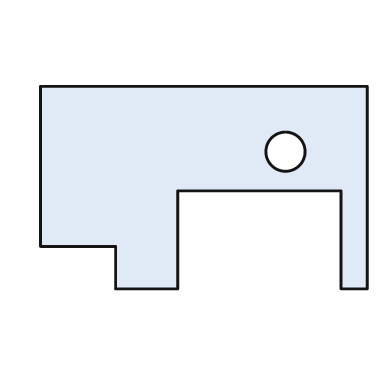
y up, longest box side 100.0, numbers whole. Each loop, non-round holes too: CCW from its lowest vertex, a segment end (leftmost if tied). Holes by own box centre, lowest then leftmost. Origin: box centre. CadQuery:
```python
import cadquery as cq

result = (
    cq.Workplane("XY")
    .moveTo(-27.0, -31.0)
    .lineTo(-8.0, -31.0)
    .lineTo(-8.0, -1.0)
    .lineTo(42.0, -1.0)
    .lineTo(42.0, -31.0)
    .lineTo(50.0, -31.0)
    .lineTo(50.0, 31.0)
    .lineTo(-50.0, 31.0)
    .lineTo(-50.0, -18.0)
    .lineTo(-27.0, -18.0)
    .close()
    .moveTo(25.0, 11.0)
    .circle(6.0)
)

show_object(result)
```